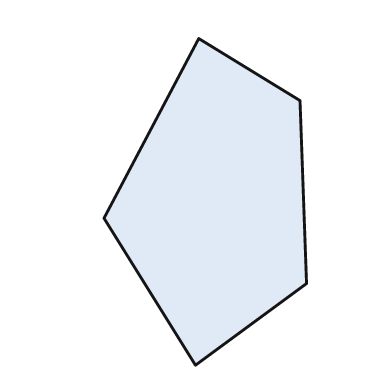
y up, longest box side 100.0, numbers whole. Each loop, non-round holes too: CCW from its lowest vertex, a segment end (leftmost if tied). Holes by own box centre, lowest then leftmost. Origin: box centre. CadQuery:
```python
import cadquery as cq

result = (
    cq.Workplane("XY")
    .moveTo(-3.0, -50.0)
    .lineTo(31.0, -25.0)
    .lineTo(29.0, 31.0)
    .lineTo(-2.0, 50.0)
    .lineTo(-31.0, -5.0)
    .close()
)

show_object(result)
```